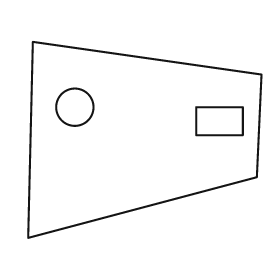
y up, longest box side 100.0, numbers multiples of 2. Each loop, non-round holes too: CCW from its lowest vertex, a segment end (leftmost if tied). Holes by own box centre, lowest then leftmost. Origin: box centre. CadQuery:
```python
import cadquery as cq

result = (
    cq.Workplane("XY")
    .moveTo(-50.0, -42.0)
    .lineTo(48.0, -16.0)
    .lineTo(50.0, 28.0)
    .lineTo(-48.0, 42.0)
    .close()
    .moveTo(22.0, 2.0)
    .lineTo(42.0, 2.0)
    .lineTo(42.0, 14.0)
    .lineTo(22.0, 14.0)
    .close()
    .moveTo(-30.0, 14.0)
    .circle(8.0)
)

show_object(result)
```